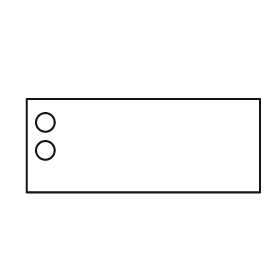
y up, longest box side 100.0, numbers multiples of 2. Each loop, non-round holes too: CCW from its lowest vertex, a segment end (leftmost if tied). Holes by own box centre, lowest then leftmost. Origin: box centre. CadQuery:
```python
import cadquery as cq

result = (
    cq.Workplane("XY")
    .moveTo(-50.0, -20.0)
    .lineTo(50.0, -20.0)
    .lineTo(50.0, 20.0)
    .lineTo(-50.0, 20.0)
    .close()
    .moveTo(-42.0, -2.0)
    .circle(4.0)
    .moveTo(-42.0, 10.0)
    .circle(4.0)
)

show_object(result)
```